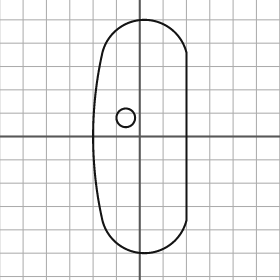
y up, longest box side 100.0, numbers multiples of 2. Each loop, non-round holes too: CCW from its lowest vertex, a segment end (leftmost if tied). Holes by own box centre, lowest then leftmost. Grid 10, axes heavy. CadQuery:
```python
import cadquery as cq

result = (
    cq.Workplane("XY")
    .moveTo(-16.0, -36.0)
    .threePointArc((2.0, -50.0), (20.0, -36.0))
    .lineTo(20.0, 36.0)
    .threePointArc((2.0, 50.0), (-16.0, 36.0))
    .threePointArc((-20.0, 0.0), (-16.0, -36.0))
    .close()
    .moveTo(-6.0, 8.0)
    .circle(4.0)
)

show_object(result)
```